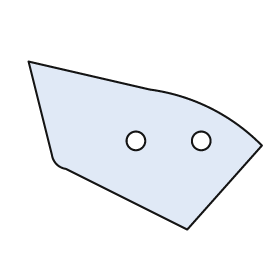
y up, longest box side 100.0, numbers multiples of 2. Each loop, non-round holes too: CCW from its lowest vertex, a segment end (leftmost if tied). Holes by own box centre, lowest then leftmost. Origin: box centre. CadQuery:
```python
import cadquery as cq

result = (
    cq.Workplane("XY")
    .moveTo(18.0, -36.0)
    .lineTo(50.0, 0.0)
    .threePointArc((28.0, 16.0), (2.0, 24.0))
    .lineTo(-50.0, 36.0)
    .lineTo(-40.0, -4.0)
    .threePointArc((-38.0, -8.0), (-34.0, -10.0))
    .close()
    .moveTo(-4.0, 2.0)
    .circle(4.0)
    .moveTo(24.0, 2.0)
    .circle(4.0)
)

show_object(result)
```